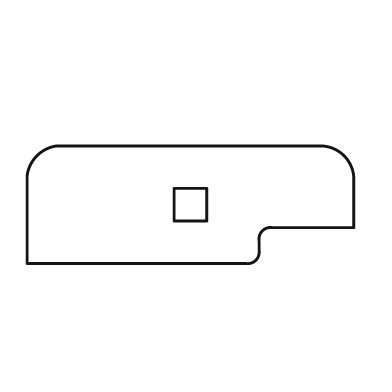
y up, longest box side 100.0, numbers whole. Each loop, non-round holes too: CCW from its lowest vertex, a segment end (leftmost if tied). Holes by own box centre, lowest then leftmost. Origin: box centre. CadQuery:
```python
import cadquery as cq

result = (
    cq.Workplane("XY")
    .moveTo(-50.0, -18.0)
    .lineTo(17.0, -18.0)
    .threePointArc((20.0, -17.0), (21.0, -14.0))
    .lineTo(21.0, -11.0)
    .threePointArc((22.0, -8.0), (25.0, -7.0))
    .lineTo(50.0, -7.0)
    .lineTo(50.0, 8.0)
    .threePointArc((47.0, 15.0), (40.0, 18.0))
    .lineTo(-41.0, 18.0)
    .threePointArc((-47.0, 15.0), (-50.0, 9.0))
    .close()
    .moveTo(-5.0, -5.0)
    .lineTo(5.0, -5.0)
    .lineTo(5.0, 5.0)
    .lineTo(-5.0, 5.0)
    .close()
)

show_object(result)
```